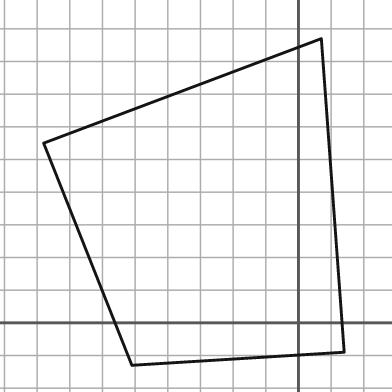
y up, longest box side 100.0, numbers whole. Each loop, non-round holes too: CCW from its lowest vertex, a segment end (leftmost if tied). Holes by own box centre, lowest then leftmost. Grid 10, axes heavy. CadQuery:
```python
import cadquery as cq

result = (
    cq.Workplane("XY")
    .moveTo(-51.0, -13.0)
    .lineTo(14.0, -9.0)
    .lineTo(7.0, 87.0)
    .lineTo(-78.0, 55.0)
    .close()
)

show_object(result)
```